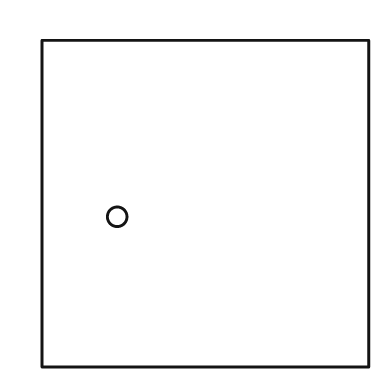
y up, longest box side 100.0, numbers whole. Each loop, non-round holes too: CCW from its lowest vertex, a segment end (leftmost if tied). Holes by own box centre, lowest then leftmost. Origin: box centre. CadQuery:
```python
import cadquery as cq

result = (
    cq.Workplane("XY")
    .moveTo(-50.0, -50.0)
    .lineTo(50.0, -50.0)
    .lineTo(50.0, 50.0)
    .lineTo(-50.0, 50.0)
    .close()
    .moveTo(-27.0, -4.0)
    .circle(3.0)
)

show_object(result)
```